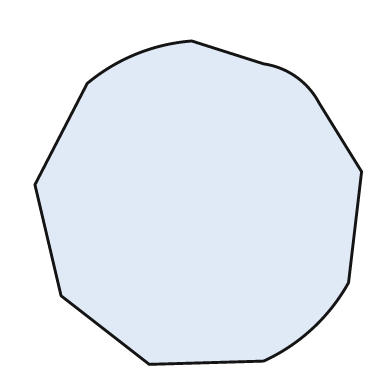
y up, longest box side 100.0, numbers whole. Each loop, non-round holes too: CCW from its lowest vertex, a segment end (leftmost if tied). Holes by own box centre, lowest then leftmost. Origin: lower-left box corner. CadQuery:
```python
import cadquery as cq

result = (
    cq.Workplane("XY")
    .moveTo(35.0, 0.0)
    .lineTo(70.0, 1.0)
    .threePointArc((85.0, 11.0), (96.0, 25.0))
    .lineTo(100.0, 59.0)
    .lineTo(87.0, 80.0)
    .threePointArc((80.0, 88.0), (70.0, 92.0))
    .lineTo(48.0, 99.0)
    .threePointArc((31.0, 95.0), (16.0, 86.0))
    .lineTo(0.0, 55.0)
    .lineTo(8.0, 21.0)
    .close()
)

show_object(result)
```